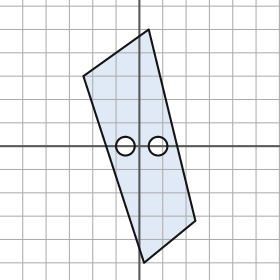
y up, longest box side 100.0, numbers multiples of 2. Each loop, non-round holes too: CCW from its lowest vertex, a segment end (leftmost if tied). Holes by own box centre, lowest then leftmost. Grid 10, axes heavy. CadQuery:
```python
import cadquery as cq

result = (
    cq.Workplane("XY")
    .moveTo(2.0, -50.0)
    .lineTo(24.0, -32.0)
    .lineTo(4.0, 50.0)
    .lineTo(-24.0, 30.0)
    .close()
    .moveTo(-6.0, 0.0)
    .circle(4.0)
    .moveTo(8.0, 0.0)
    .circle(4.0)
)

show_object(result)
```